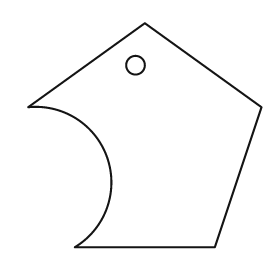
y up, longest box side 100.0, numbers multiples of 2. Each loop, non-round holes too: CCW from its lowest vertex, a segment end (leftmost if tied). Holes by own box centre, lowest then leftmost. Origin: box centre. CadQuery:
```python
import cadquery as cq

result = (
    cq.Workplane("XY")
    .moveTo(-30.0, -48.0)
    .lineTo(30.0, -48.0)
    .lineTo(50.0, 12.0)
    .lineTo(0.0, 48.0)
    .lineTo(-50.0, 12.0)
    .threePointArc((-16.0, -10.0), (-30.0, -48.0))
    .close()
    .moveTo(-4.0, 30.0)
    .circle(4.0)
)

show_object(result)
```